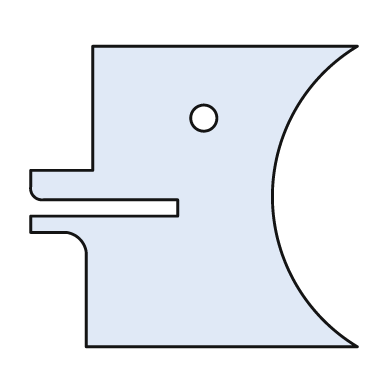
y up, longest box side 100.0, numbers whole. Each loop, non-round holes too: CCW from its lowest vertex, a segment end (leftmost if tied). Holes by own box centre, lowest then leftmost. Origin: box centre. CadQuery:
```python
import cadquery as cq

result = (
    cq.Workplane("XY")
    .moveTo(-33.0, -46.0)
    .lineTo(50.0, -46.0)
    .threePointArc((24.0, 0.0), (50.0, 46.0))
    .lineTo(-31.0, 46.0)
    .lineTo(-31.0, 8.0)
    .lineTo(-50.0, 8.0)
    .lineTo(-50.0, 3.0)
    .threePointArc((-49.0, 0.0), (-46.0, -1.0))
    .lineTo(-5.0, -1.0)
    .lineTo(-5.0, -6.0)
    .lineTo(-50.0, -6.0)
    .lineTo(-50.0, -11.0)
    .lineTo(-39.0, -11.0)
    .threePointArc((-35.0, -13.0), (-33.0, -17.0))
    .close()
    .moveTo(3.0, 24.0)
    .circle(4.0)
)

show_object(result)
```